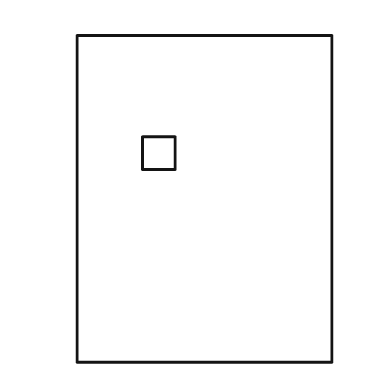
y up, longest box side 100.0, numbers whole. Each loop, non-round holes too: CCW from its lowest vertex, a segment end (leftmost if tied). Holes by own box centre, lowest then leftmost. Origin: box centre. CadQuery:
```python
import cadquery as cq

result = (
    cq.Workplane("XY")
    .moveTo(-39.0, -50.0)
    .lineTo(39.0, -50.0)
    .lineTo(39.0, 50.0)
    .lineTo(-39.0, 50.0)
    .close()
    .moveTo(-19.0, 9.0)
    .lineTo(-9.0, 9.0)
    .lineTo(-9.0, 19.0)
    .lineTo(-19.0, 19.0)
    .close()
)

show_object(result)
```